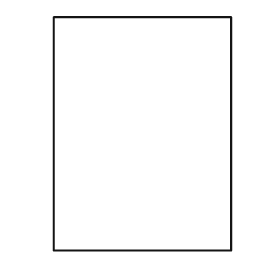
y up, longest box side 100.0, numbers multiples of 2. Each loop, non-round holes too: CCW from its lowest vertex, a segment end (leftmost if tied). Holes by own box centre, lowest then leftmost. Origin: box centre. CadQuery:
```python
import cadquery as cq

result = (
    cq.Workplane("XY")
    .moveTo(-38.0, -50.0)
    .lineTo(38.0, -50.0)
    .lineTo(38.0, 50.0)
    .lineTo(-38.0, 50.0)
    .close()
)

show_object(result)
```